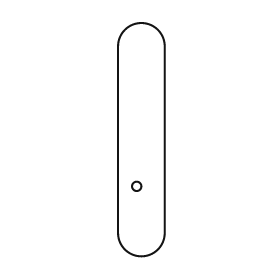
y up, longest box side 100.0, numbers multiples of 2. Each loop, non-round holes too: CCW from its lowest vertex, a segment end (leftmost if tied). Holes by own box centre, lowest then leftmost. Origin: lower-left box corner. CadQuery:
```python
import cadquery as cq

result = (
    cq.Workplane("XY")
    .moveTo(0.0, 10.0)
    .threePointArc((10.0, 0.0), (20.0, 10.0))
    .lineTo(20.0, 90.0)
    .threePointArc((10.0, 100.0), (0.0, 90.0))
    .close()
    .moveTo(8.0, 30.0)
    .circle(2.0)
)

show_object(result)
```